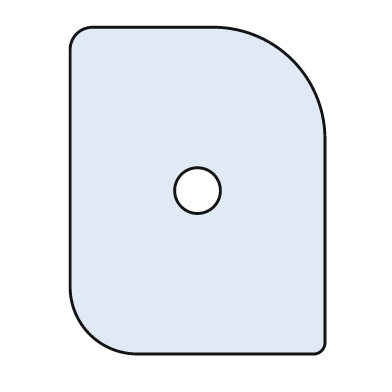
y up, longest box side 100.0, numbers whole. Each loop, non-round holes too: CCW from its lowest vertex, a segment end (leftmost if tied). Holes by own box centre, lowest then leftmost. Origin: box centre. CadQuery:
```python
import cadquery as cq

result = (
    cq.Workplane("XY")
    .moveTo(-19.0, -50.0)
    .lineTo(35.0, -50.0)
    .threePointArc((38.0, -49.0), (39.0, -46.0))
    .lineTo(39.0, 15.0)
    .threePointArc((29.0, 40.0), (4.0, 50.0))
    .lineTo(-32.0, 50.0)
    .threePointArc((-37.0, 48.0), (-39.0, 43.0))
    .lineTo(-39.0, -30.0)
    .threePointArc((-33.0, -44.0), (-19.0, -50.0))
    .close()
    .moveTo(0.0, 0.0)
    .circle(7.0)
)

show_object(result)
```